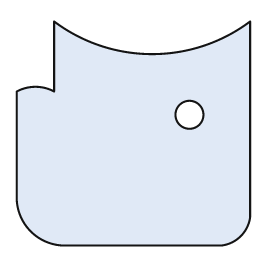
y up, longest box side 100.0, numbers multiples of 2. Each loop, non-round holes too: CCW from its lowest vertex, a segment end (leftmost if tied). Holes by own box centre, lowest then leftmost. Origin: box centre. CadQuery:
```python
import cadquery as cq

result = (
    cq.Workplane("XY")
    .moveTo(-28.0, -48.0)
    .lineTo(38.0, -48.0)
    .threePointArc((46.0, -44.0), (50.0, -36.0))
    .lineTo(50.0, 48.0)
    .threePointArc((8.0, 34.0), (-34.0, 48.0))
    .lineTo(-34.0, 18.0)
    .threePointArc((-42.0, 20.0), (-50.0, 18.0))
    .lineTo(-50.0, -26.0)
    .threePointArc((-44.0, -42.0), (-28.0, -48.0))
    .close()
    .moveTo(24.0, 8.0)
    .circle(6.0)
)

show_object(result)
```